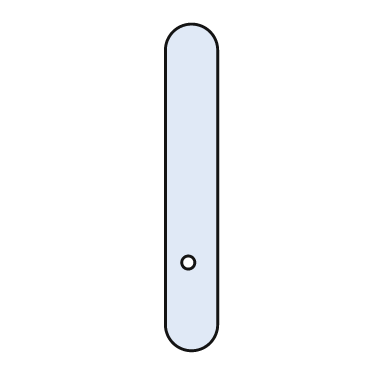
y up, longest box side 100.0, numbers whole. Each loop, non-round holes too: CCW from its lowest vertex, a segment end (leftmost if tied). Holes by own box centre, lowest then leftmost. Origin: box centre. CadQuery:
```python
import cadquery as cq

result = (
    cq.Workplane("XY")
    .moveTo(-8.0, -42.0)
    .threePointArc((0.0, -50.0), (8.0, -42.0))
    .lineTo(8.0, 42.0)
    .threePointArc((0.0, 50.0), (-8.0, 42.0))
    .close()
    .moveTo(-1.0, -23.0)
    .circle(2.0)
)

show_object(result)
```